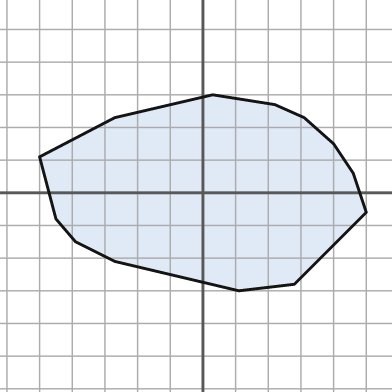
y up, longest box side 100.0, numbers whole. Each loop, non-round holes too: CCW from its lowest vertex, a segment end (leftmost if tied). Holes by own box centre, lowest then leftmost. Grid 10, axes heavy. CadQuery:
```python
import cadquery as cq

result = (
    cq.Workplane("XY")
    .moveTo(11.0, -30.0)
    .lineTo(28.0, -28.0)
    .lineTo(50.0, -6.0)
    .lineTo(46.0, 6.0)
    .lineTo(40.0, 15.0)
    .lineTo(31.0, 23.0)
    .lineTo(22.0, 27.0)
    .lineTo(3.0, 30.0)
    .lineTo(-27.0, 23.0)
    .lineTo(-50.0, 11.0)
    .lineTo(-45.0, -8.0)
    .lineTo(-39.0, -15.0)
    .lineTo(-27.0, -21.0)
    .close()
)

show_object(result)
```